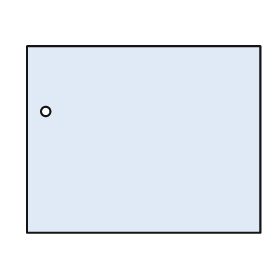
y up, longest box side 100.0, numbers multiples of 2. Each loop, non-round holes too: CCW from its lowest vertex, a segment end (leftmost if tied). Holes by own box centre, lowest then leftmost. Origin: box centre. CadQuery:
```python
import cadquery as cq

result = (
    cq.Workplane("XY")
    .moveTo(-50.0, -40.0)
    .lineTo(50.0, -40.0)
    .lineTo(50.0, 40.0)
    .lineTo(-50.0, 40.0)
    .close()
    .moveTo(-42.0, 12.0)
    .circle(2.0)
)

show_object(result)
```